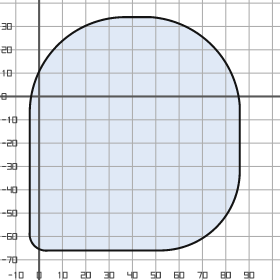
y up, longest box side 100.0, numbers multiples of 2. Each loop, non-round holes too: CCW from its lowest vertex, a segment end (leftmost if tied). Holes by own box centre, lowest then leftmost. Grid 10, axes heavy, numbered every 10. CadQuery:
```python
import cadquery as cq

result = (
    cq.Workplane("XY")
    .moveTo(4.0, -66.0)
    .lineTo(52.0, -66.0)
    .threePointArc((76.0, -56.0), (86.0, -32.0))
    .lineTo(86.0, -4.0)
    .threePointArc((74.0, 22.0), (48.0, 34.0))
    .lineTo(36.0, 34.0)
    .threePointArc((8.0, 22.0), (-4.0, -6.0))
    .lineTo(-4.0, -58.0)
    .threePointArc((-2.0, -64.0), (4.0, -66.0))
    .close()
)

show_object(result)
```